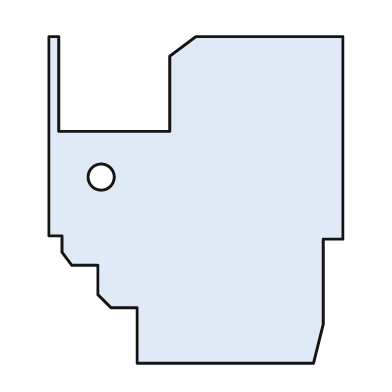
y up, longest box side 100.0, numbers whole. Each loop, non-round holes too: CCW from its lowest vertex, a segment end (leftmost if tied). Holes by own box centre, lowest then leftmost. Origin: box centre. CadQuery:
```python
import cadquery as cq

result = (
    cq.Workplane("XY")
    .moveTo(-18.0, -50.0)
    .lineTo(36.0, -50.0)
    .lineTo(39.0, -38.0)
    .lineTo(39.0, -12.0)
    .lineTo(45.0, -12.0)
    .lineTo(45.0, 50.0)
    .lineTo(0.0, 50.0)
    .lineTo(-8.0, 44.0)
    .lineTo(-8.0, 21.0)
    .lineTo(-42.0, 21.0)
    .lineTo(-42.0, 50.0)
    .lineTo(-45.0, 50.0)
    .lineTo(-45.0, -11.0)
    .lineTo(-41.0, -11.0)
    .lineTo(-41.0, -16.0)
    .lineTo(-38.0, -20.0)
    .lineTo(-30.0, -20.0)
    .lineTo(-30.0, -29.0)
    .lineTo(-26.0, -33.0)
    .lineTo(-18.0, -33.0)
    .close()
    .moveTo(-29.0, 7.0)
    .circle(4.0)
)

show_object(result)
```